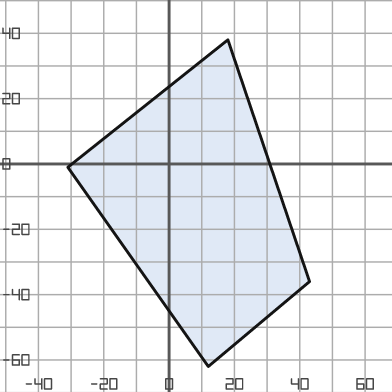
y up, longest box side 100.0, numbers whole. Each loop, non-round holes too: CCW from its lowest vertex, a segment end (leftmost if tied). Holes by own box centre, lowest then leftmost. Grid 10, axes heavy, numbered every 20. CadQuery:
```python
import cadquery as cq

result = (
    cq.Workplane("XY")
    .moveTo(12.0, -62.0)
    .lineTo(43.0, -36.0)
    .lineTo(18.0, 38.0)
    .lineTo(-31.0, -1.0)
    .close()
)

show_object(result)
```